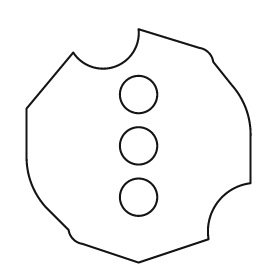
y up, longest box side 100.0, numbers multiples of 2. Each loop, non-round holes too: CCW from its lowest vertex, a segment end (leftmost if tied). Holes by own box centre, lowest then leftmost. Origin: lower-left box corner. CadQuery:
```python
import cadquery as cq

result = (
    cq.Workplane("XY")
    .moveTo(48.0, 0.0)
    .lineTo(78.0, 10.0)
    .threePointArc((82.0, 26.0), (96.0, 34.0))
    .lineTo(96.0, 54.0)
    .threePointArc((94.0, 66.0), (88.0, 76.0))
    .lineTo(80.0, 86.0)
    .threePointArc((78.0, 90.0), (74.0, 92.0))
    .lineTo(48.0, 100.0)
    .threePointArc((38.0, 84.0), (20.0, 90.0))
    .lineTo(0.0, 66.0)
    .lineTo(0.0, 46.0)
    .threePointArc((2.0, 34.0), (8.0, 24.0))
    .lineTo(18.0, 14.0)
    .threePointArc((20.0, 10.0), (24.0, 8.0))
    .close()
    .moveTo(48.0, 28.0)
    .circle(8.0)
    .moveTo(48.0, 50.0)
    .circle(8.0)
    .moveTo(48.0, 72.0)
    .circle(8.0)
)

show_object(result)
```